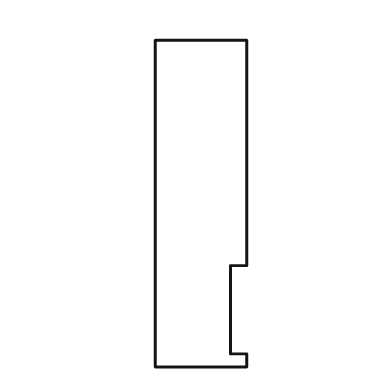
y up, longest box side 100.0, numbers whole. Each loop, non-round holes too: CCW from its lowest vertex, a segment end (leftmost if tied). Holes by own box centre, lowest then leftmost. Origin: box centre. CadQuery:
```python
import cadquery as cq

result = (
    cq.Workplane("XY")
    .moveTo(-14.0, -50.0)
    .lineTo(14.0, -50.0)
    .lineTo(14.0, -46.0)
    .lineTo(9.0, -46.0)
    .lineTo(9.0, -19.0)
    .lineTo(14.0, -19.0)
    .lineTo(14.0, 50.0)
    .lineTo(-14.0, 50.0)
    .close()
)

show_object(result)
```